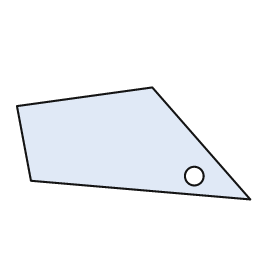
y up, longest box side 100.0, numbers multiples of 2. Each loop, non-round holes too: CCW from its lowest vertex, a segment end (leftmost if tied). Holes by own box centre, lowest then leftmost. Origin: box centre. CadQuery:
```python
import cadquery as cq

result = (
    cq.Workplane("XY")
    .moveTo(50.0, -24.0)
    .lineTo(8.0, 24.0)
    .lineTo(-50.0, 16.0)
    .lineTo(-44.0, -16.0)
    .close()
    .moveTo(26.0, -14.0)
    .circle(4.0)
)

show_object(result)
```